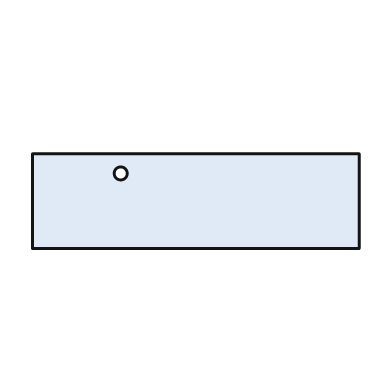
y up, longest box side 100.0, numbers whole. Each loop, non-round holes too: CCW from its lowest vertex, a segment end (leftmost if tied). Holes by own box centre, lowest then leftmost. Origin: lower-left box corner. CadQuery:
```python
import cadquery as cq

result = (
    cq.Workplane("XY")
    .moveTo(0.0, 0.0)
    .lineTo(100.0, 0.0)
    .lineTo(100.0, 29.0)
    .lineTo(0.0, 29.0)
    .close()
    .moveTo(27.0, 23.0)
    .circle(2.0)
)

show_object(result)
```